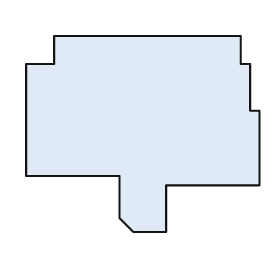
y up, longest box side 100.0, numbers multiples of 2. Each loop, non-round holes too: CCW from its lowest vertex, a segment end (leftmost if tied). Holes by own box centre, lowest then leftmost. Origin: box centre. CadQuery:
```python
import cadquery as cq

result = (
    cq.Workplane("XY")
    .moveTo(-4.0, -42.0)
    .lineTo(10.0, -42.0)
    .lineTo(10.0, -22.0)
    .lineTo(50.0, -22.0)
    .lineTo(50.0, 10.0)
    .lineTo(46.0, 10.0)
    .lineTo(46.0, 30.0)
    .lineTo(42.0, 30.0)
    .lineTo(42.0, 42.0)
    .lineTo(-38.0, 42.0)
    .lineTo(-38.0, 30.0)
    .lineTo(-50.0, 30.0)
    .lineTo(-50.0, -18.0)
    .lineTo(-10.0, -18.0)
    .lineTo(-10.0, -36.0)
    .close()
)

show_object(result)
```